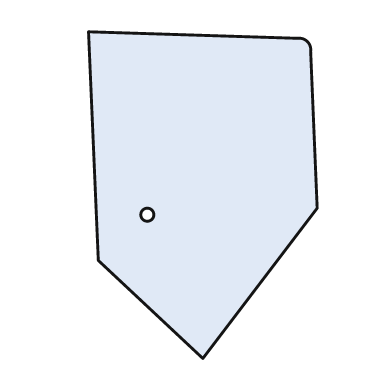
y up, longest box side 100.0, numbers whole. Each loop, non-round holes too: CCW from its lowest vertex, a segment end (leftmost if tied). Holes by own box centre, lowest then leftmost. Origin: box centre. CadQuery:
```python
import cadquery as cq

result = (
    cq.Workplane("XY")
    .moveTo(0.0, -50.0)
    .lineTo(35.0, -4.0)
    .lineTo(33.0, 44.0)
    .threePointArc((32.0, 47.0), (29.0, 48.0))
    .lineTo(-35.0, 50.0)
    .lineTo(-32.0, -20.0)
    .close()
    .moveTo(-17.0, -6.0)
    .circle(2.0)
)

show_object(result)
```